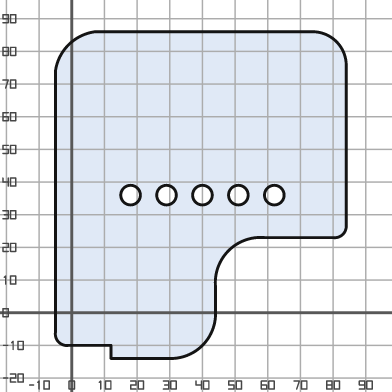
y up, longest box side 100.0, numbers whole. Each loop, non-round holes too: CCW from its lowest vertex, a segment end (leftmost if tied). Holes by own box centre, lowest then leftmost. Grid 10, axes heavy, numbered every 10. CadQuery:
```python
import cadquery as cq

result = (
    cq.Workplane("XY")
    .moveTo(12.0, -14.0)
    .lineTo(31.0, -14.0)
    .threePointArc((40.0, -10.0), (44.0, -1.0))
    .lineTo(44.0, 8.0)
    .threePointArc((48.0, 19.0), (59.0, 23.0))
    .lineTo(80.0, 23.0)
    .threePointArc((83.0, 24.0), (84.0, 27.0))
    .lineTo(84.0, 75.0)
    .threePointArc((81.0, 83.0), (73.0, 86.0))
    .lineTo(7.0, 86.0)
    .threePointArc((-1.0, 82.0), (-5.0, 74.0))
    .lineTo(-5.0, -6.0)
    .threePointArc((-4.0, -9.0), (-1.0, -10.0))
    .lineTo(12.0, -10.0)
    .close()
    .moveTo(18.0, 36.0)
    .circle(3.0)
    .moveTo(29.0, 36.0)
    .circle(3.0)
    .moveTo(40.0, 36.0)
    .circle(3.0)
    .moveTo(51.0, 36.0)
    .circle(3.0)
    .moveTo(62.0, 36.0)
    .circle(3.0)
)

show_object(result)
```